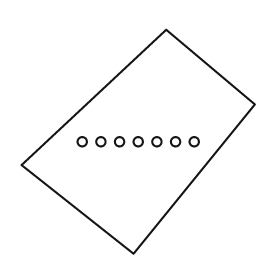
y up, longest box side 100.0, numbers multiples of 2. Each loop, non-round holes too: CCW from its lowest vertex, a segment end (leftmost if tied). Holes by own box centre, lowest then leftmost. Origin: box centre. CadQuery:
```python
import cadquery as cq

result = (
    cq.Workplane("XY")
    .moveTo(-2.0, -48.0)
    .lineTo(50.0, 16.0)
    .lineTo(12.0, 48.0)
    .lineTo(-50.0, -10.0)
    .close()
    .moveTo(-24.0, 0.0)
    .circle(2.0)
    .moveTo(-16.0, 0.0)
    .circle(2.0)
    .moveTo(-8.0, 0.0)
    .circle(2.0)
    .moveTo(0.0, 0.0)
    .circle(2.0)
    .moveTo(8.0, 0.0)
    .circle(2.0)
    .moveTo(16.0, 0.0)
    .circle(2.0)
    .moveTo(24.0, 0.0)
    .circle(2.0)
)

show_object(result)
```